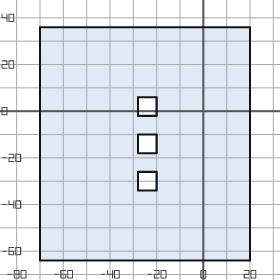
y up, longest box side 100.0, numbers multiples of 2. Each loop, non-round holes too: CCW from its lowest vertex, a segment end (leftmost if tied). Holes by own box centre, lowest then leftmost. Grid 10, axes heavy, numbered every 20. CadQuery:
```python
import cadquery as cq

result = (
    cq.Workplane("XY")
    .moveTo(-70.0, -64.0)
    .lineTo(20.0, -64.0)
    .lineTo(20.0, 36.0)
    .lineTo(-70.0, 36.0)
    .close()
    .moveTo(-28.0, -34.0)
    .lineTo(-20.0, -34.0)
    .lineTo(-20.0, -26.0)
    .lineTo(-28.0, -26.0)
    .close()
    .moveTo(-28.0, -18.0)
    .lineTo(-20.0, -18.0)
    .lineTo(-20.0, -10.0)
    .lineTo(-28.0, -10.0)
    .close()
    .moveTo(-28.0, -2.0)
    .lineTo(-20.0, -2.0)
    .lineTo(-20.0, 6.0)
    .lineTo(-28.0, 6.0)
    .close()
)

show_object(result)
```